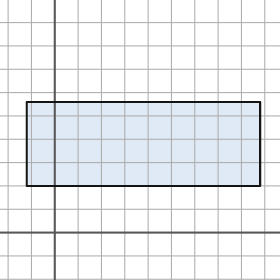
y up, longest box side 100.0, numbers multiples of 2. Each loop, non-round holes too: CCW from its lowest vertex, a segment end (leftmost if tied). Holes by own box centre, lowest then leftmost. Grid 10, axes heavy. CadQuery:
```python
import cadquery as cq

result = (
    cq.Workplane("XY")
    .moveTo(-12.0, 20.0)
    .lineTo(88.0, 20.0)
    .lineTo(88.0, 56.0)
    .lineTo(-12.0, 56.0)
    .close()
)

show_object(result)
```